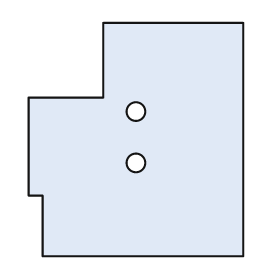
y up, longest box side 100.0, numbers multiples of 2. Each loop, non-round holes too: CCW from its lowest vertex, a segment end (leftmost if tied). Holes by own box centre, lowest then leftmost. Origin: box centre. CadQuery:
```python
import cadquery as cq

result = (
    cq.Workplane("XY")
    .moveTo(-40.0, -50.0)
    .lineTo(46.0, -50.0)
    .lineTo(46.0, 50.0)
    .lineTo(-14.0, 50.0)
    .lineTo(-14.0, 18.0)
    .lineTo(-46.0, 18.0)
    .lineTo(-46.0, -24.0)
    .lineTo(-40.0, -24.0)
    .close()
    .moveTo(0.0, -10.0)
    .circle(4.0)
    .moveTo(0.0, 12.0)
    .circle(4.0)
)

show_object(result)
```